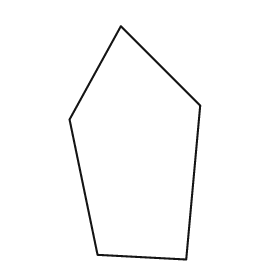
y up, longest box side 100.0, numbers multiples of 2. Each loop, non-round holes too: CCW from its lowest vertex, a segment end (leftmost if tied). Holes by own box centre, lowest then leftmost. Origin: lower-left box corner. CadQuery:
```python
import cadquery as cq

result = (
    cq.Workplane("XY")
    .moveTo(50.0, 0.0)
    .lineTo(56.0, 66.0)
    .lineTo(22.0, 100.0)
    .lineTo(0.0, 60.0)
    .lineTo(12.0, 2.0)
    .close()
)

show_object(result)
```